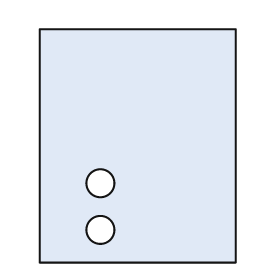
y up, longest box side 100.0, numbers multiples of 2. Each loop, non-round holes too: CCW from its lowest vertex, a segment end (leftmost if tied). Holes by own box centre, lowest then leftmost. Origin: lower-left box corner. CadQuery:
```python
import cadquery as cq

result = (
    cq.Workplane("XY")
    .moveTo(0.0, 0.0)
    .lineTo(84.0, 0.0)
    .lineTo(84.0, 100.0)
    .lineTo(0.0, 100.0)
    .close()
    .moveTo(26.0, 14.0)
    .circle(6.0)
    .moveTo(26.0, 34.0)
    .circle(6.0)
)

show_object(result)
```